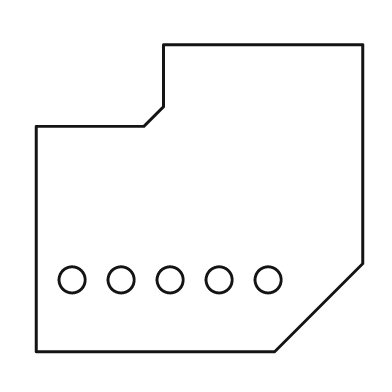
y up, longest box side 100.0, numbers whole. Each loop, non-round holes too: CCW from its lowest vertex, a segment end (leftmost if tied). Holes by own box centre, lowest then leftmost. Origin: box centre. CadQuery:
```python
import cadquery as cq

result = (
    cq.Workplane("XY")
    .moveTo(-50.0, -47.0)
    .lineTo(23.0, -47.0)
    .lineTo(50.0, -20.0)
    .lineTo(50.0, 47.0)
    .lineTo(-11.0, 47.0)
    .lineTo(-11.0, 28.0)
    .lineTo(-17.0, 22.0)
    .lineTo(-50.0, 22.0)
    .close()
    .moveTo(-39.0, -25.0)
    .circle(4.0)
    .moveTo(-24.0, -25.0)
    .circle(4.0)
    .moveTo(-9.0, -25.0)
    .circle(4.0)
    .moveTo(6.0, -25.0)
    .circle(4.0)
    .moveTo(21.0, -25.0)
    .circle(4.0)
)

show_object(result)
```